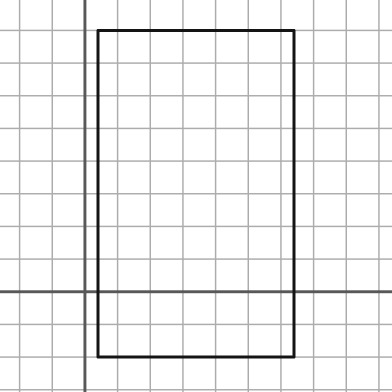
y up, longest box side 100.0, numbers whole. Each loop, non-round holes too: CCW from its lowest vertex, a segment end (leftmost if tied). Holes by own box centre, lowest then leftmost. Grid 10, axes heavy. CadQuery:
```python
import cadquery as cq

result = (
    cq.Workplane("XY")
    .moveTo(4.0, -20.0)
    .lineTo(64.0, -20.0)
    .lineTo(64.0, 80.0)
    .lineTo(4.0, 80.0)
    .close()
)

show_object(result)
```